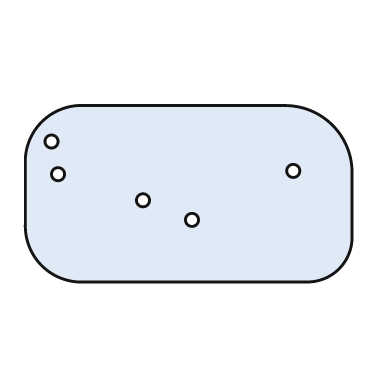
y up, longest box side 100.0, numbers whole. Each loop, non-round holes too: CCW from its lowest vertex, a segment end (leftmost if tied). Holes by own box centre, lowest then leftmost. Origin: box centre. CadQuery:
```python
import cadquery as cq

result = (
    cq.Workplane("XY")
    .moveTo(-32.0, -27.0)
    .lineTo(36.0, -27.0)
    .threePointArc((46.0, -23.0), (50.0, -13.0))
    .lineTo(50.0, 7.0)
    .threePointArc((44.0, 21.0), (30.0, 27.0))
    .lineTo(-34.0, 27.0)
    .threePointArc((-45.0, 22.0), (-50.0, 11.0))
    .lineTo(-50.0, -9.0)
    .threePointArc((-45.0, -22.0), (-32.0, -27.0))
    .close()
    .moveTo(1.0, -8.0)
    .circle(2.0)
    .moveTo(-14.0, -2.0)
    .circle(2.0)
    .moveTo(-40.0, 6.0)
    .circle(2.0)
    .moveTo(32.0, 7.0)
    .circle(2.0)
    .moveTo(-42.0, 16.0)
    .circle(2.0)
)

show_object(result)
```